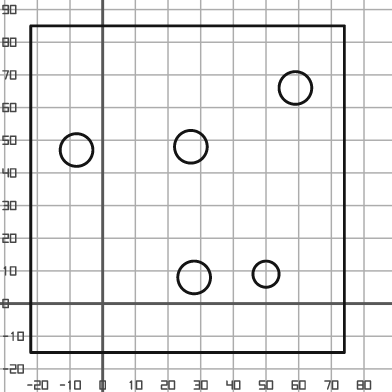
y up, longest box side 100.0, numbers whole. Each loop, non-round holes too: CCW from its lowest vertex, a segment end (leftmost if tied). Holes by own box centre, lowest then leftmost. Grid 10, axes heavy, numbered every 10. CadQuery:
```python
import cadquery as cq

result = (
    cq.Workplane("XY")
    .moveTo(-22.0, -15.0)
    .lineTo(74.0, -15.0)
    .lineTo(74.0, 85.0)
    .lineTo(-22.0, 85.0)
    .close()
    .moveTo(28.0, 8.0)
    .circle(5.0)
    .moveTo(50.0, 9.0)
    .circle(4.0)
    .moveTo(-8.0, 47.0)
    .circle(5.0)
    .moveTo(27.0, 48.0)
    .circle(5.0)
    .moveTo(59.0, 66.0)
    .circle(5.0)
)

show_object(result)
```